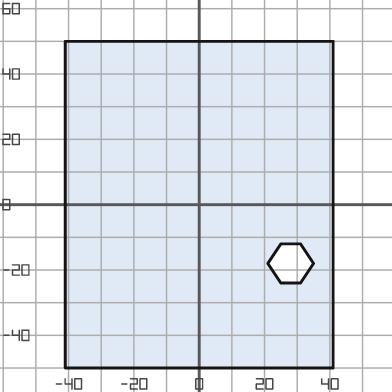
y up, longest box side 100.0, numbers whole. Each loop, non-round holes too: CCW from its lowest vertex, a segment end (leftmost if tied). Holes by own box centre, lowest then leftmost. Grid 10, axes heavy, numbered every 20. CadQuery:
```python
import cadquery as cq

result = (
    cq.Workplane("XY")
    .moveTo(-41.0, -50.0)
    .lineTo(41.0, -50.0)
    .lineTo(41.0, 50.0)
    .lineTo(-41.0, 50.0)
    .close()
    .moveTo(25.0, -24.0)
    .lineTo(31.0, -24.0)
    .lineTo(35.0, -18.0)
    .lineTo(31.0, -12.0)
    .lineTo(25.0, -12.0)
    .lineTo(21.0, -18.0)
    .close()
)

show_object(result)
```